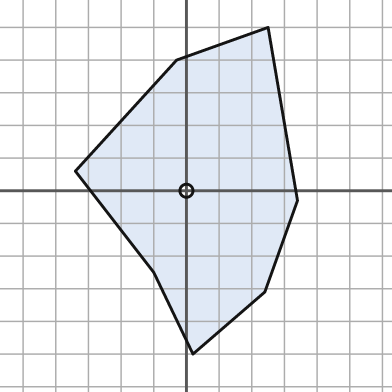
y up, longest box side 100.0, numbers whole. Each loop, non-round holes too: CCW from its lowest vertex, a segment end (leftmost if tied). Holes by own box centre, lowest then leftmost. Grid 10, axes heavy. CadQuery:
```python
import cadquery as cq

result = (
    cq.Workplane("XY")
    .moveTo(2.0, -50.0)
    .lineTo(24.0, -31.0)
    .lineTo(34.0, -3.0)
    .lineTo(25.0, 50.0)
    .lineTo(-3.0, 40.0)
    .lineTo(-34.0, 6.0)
    .lineTo(-10.0, -25.0)
    .close()
    .moveTo(0.0, 0.0)
    .circle(2.0)
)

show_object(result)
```